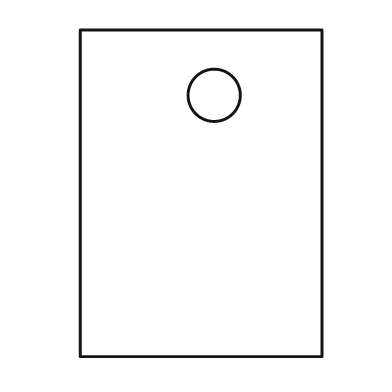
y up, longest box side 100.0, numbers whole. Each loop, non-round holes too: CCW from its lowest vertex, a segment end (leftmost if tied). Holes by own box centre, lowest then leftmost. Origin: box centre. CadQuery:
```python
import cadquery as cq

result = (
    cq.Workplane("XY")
    .moveTo(-37.0, -50.0)
    .lineTo(37.0, -50.0)
    .lineTo(37.0, 50.0)
    .lineTo(-37.0, 50.0)
    .close()
    .moveTo(4.0, 30.0)
    .circle(8.0)
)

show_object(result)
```